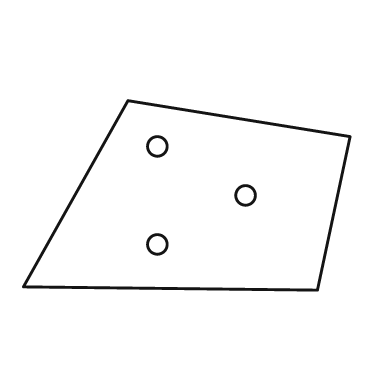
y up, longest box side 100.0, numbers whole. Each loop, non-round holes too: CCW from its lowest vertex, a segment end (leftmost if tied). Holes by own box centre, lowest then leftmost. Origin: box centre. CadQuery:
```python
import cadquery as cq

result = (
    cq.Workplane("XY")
    .moveTo(40.0, -29.0)
    .lineTo(50.0, 18.0)
    .lineTo(-18.0, 29.0)
    .lineTo(-50.0, -28.0)
    .close()
    .moveTo(-9.0, -15.0)
    .circle(3.0)
    .moveTo(18.0, 0.0)
    .circle(3.0)
    .moveTo(-9.0, 15.0)
    .circle(3.0)
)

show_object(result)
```